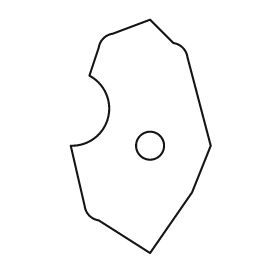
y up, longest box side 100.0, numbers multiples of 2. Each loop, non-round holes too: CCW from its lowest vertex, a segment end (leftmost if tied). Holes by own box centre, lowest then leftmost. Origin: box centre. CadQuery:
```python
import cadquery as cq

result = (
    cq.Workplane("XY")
    .moveTo(4.0, -50.0)
    .lineTo(22.0, -24.0)
    .lineTo(30.0, -4.0)
    .lineTo(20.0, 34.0)
    .threePointArc((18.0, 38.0), (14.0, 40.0))
    .lineTo(4.0, 50.0)
    .lineTo(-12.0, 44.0)
    .threePointArc((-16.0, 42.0), (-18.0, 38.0))
    .lineTo(-22.0, 26.0)
    .threePointArc((-14.0, 8.0), (-30.0, -4.0))
    .lineTo(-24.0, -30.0)
    .threePointArc((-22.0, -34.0), (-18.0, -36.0))
    .close()
    .moveTo(4.0, -4.0)
    .circle(6.0)
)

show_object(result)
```